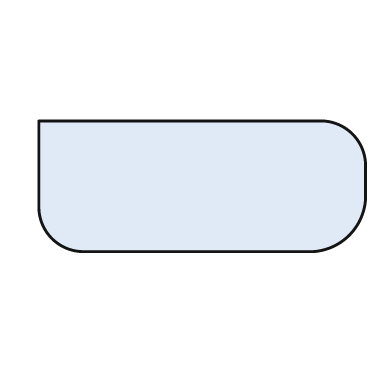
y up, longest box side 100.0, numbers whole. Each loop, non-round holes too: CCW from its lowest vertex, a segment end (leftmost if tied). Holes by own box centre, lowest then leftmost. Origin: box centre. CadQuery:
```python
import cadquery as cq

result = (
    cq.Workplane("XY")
    .moveTo(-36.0, -20.0)
    .lineTo(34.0, -20.0)
    .threePointArc((45.0, -15.0), (50.0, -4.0))
    .lineTo(50.0, 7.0)
    .threePointArc((46.0, 16.0), (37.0, 20.0))
    .lineTo(-50.0, 20.0)
    .lineTo(-50.0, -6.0)
    .threePointArc((-46.0, -16.0), (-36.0, -20.0))
    .close()
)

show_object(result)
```